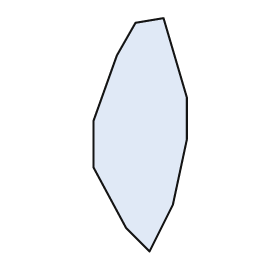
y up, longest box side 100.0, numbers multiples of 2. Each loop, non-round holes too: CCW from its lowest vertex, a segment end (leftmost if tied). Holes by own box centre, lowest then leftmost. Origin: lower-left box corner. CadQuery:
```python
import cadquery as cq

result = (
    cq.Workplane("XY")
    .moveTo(24.0, 0.0)
    .lineTo(34.0, 20.0)
    .lineTo(40.0, 48.0)
    .lineTo(40.0, 66.0)
    .lineTo(30.0, 100.0)
    .lineTo(18.0, 98.0)
    .lineTo(10.0, 84.0)
    .lineTo(0.0, 56.0)
    .lineTo(0.0, 36.0)
    .lineTo(14.0, 10.0)
    .close()
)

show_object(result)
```